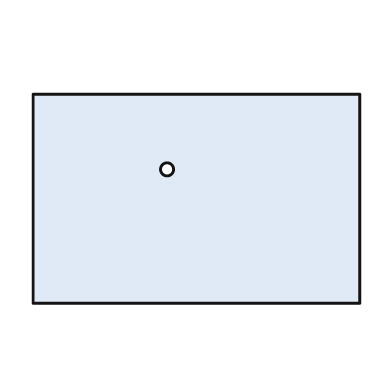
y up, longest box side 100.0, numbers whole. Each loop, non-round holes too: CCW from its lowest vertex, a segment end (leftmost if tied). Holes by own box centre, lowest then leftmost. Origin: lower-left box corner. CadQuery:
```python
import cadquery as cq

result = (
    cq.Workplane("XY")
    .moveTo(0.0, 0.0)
    .lineTo(100.0, 0.0)
    .lineTo(100.0, 64.0)
    .lineTo(0.0, 64.0)
    .close()
    .moveTo(41.0, 41.0)
    .circle(2.0)
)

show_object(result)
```